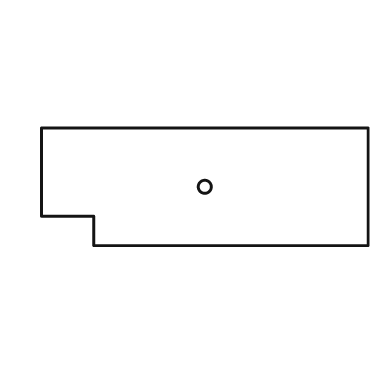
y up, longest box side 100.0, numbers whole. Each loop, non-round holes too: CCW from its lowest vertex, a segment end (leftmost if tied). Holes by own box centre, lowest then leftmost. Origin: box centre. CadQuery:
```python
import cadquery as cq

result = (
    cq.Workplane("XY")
    .moveTo(-34.0, -18.0)
    .lineTo(50.0, -18.0)
    .lineTo(50.0, 18.0)
    .lineTo(-50.0, 18.0)
    .lineTo(-50.0, -9.0)
    .lineTo(-34.0, -9.0)
    .close()
    .moveTo(0.0, 0.0)
    .circle(2.0)
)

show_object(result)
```